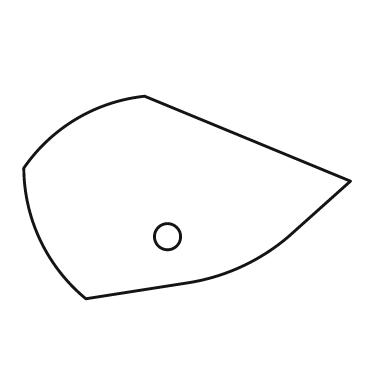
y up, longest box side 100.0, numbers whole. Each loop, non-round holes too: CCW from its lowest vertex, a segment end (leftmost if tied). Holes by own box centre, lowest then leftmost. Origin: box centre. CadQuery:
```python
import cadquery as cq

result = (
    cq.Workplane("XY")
    .moveTo(-31.0, -31.0)
    .lineTo(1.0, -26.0)
    .threePointArc((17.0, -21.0), (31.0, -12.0))
    .lineTo(50.0, 5.0)
    .lineTo(-13.0, 31.0)
    .threePointArc((-34.0, 24.0), (-50.0, 9.0))
    .threePointArc((-45.0, -13.0), (-31.0, -31.0))
    .close()
    .moveTo(-6.0, -12.0)
    .circle(4.0)
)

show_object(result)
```